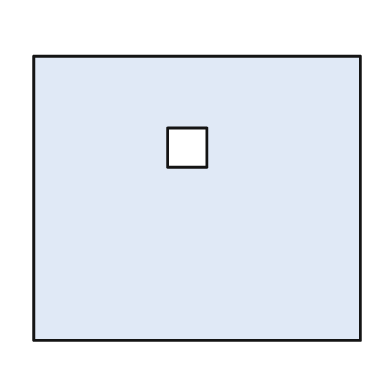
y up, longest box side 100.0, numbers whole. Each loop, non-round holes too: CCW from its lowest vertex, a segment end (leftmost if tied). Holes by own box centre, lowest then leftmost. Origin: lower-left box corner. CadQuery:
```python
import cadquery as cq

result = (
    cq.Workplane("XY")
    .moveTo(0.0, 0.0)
    .lineTo(100.0, 0.0)
    .lineTo(100.0, 87.0)
    .lineTo(0.0, 87.0)
    .close()
    .moveTo(41.0, 53.0)
    .lineTo(53.0, 53.0)
    .lineTo(53.0, 65.0)
    .lineTo(41.0, 65.0)
    .close()
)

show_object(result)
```